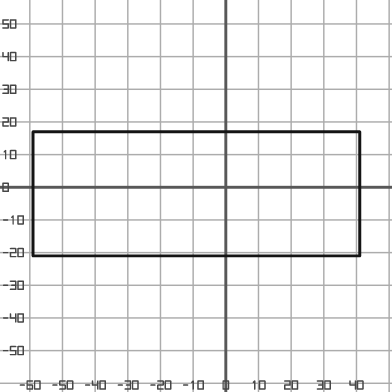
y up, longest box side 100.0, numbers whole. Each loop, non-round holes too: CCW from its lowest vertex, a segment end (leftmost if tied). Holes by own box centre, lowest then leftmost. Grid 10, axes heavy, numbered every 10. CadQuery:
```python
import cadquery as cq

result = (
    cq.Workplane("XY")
    .moveTo(-59.0, -21.0)
    .lineTo(41.0, -21.0)
    .lineTo(41.0, 17.0)
    .lineTo(-59.0, 17.0)
    .close()
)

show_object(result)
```